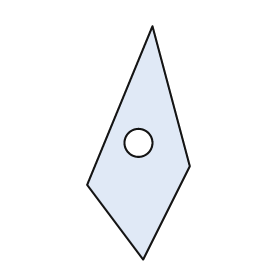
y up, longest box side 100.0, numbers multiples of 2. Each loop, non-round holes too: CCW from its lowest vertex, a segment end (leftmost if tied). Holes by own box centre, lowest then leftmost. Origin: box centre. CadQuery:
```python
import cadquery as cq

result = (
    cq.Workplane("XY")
    .moveTo(2.0, -50.0)
    .lineTo(22.0, -10.0)
    .lineTo(6.0, 50.0)
    .lineTo(-22.0, -18.0)
    .close()
    .moveTo(0.0, 0.0)
    .circle(6.0)
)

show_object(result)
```